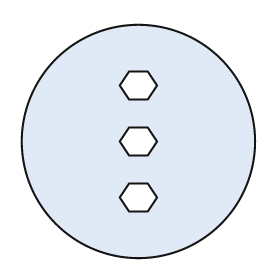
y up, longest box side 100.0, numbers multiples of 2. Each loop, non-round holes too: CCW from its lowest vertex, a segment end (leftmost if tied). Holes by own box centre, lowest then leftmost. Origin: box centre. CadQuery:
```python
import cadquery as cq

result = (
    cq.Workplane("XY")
    .moveTo(0.0, 0.0)
    .circle(50.0)
    .moveTo(-4.0, -30.0)
    .lineTo(4.0, -30.0)
    .lineTo(8.0, -24.0)
    .lineTo(4.0, -18.0)
    .lineTo(-4.0, -18.0)
    .lineTo(-8.0, -24.0)
    .close()
    .moveTo(-4.0, -6.0)
    .lineTo(4.0, -6.0)
    .lineTo(8.0, 0.0)
    .lineTo(4.0, 6.0)
    .lineTo(-4.0, 6.0)
    .lineTo(-8.0, 0.0)
    .close()
    .moveTo(-4.0, 18.0)
    .lineTo(4.0, 18.0)
    .lineTo(8.0, 24.0)
    .lineTo(4.0, 30.0)
    .lineTo(-4.0, 30.0)
    .lineTo(-8.0, 24.0)
    .close()
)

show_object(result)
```